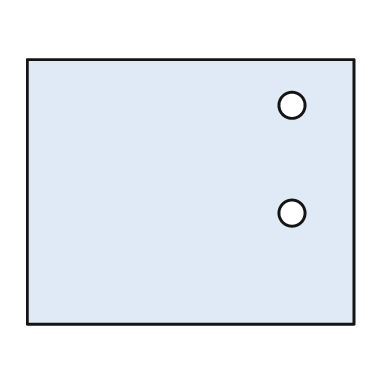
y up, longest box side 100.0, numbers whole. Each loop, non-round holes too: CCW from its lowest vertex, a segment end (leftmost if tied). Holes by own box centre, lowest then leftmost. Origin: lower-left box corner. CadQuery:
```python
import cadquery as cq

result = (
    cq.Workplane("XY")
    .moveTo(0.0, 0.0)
    .lineTo(100.0, 0.0)
    .lineTo(100.0, 81.0)
    .lineTo(0.0, 81.0)
    .close()
    .moveTo(81.0, 34.0)
    .circle(4.0)
    .moveTo(81.0, 67.0)
    .circle(4.0)
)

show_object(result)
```